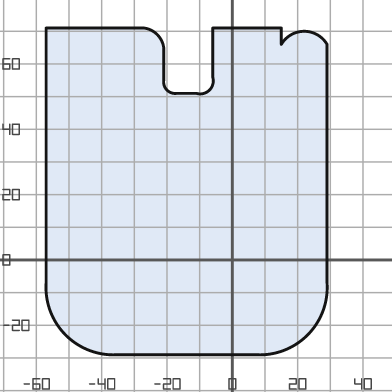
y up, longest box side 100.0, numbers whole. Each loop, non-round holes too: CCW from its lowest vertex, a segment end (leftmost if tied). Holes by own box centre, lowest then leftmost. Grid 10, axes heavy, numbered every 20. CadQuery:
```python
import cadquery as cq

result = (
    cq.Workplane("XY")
    .moveTo(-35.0, -29.0)
    .lineTo(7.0, -29.0)
    .threePointArc((23.0, -23.0), (29.0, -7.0))
    .lineTo(29.0, 66.0)
    .threePointArc((22.0, 70.0), (15.0, 66.0))
    .lineTo(15.0, 71.0)
    .lineTo(-6.0, 71.0)
    .lineTo(-6.0, 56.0)
    .threePointArc((-7.0, 52.0), (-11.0, 51.0))
    .lineTo(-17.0, 51.0)
    .threePointArc((-20.0, 52.0), (-21.0, 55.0))
    .lineTo(-21.0, 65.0)
    .threePointArc((-23.0, 69.0), (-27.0, 71.0))
    .lineTo(-57.0, 71.0)
    .lineTo(-57.0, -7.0)
    .threePointArc((-51.0, -23.0), (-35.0, -29.0))
    .close()
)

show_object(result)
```